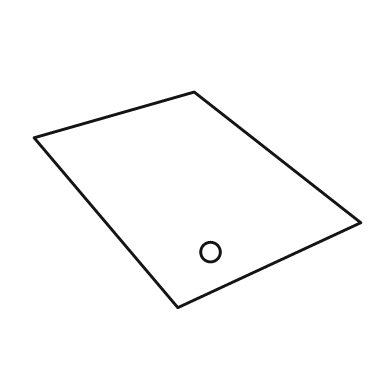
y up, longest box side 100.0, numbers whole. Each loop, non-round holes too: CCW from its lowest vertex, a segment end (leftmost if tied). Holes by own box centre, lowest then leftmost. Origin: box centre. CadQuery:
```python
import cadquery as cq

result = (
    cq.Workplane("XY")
    .moveTo(-6.0, -33.0)
    .lineTo(50.0, -7.0)
    .lineTo(-1.0, 33.0)
    .lineTo(-50.0, 19.0)
    .close()
    .moveTo(4.0, -16.0)
    .circle(3.0)
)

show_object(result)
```